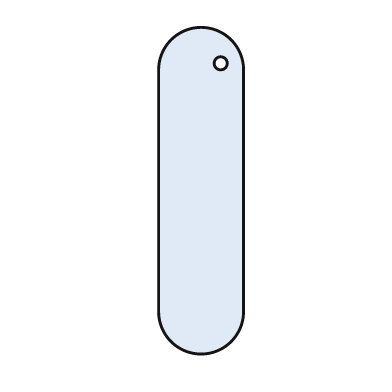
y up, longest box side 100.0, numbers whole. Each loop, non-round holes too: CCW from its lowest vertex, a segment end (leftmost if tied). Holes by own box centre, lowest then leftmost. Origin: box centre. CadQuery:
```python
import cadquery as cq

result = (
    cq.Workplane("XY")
    .moveTo(-13.0, -37.0)
    .threePointArc((0.0, -50.0), (13.0, -37.0))
    .lineTo(13.0, 37.0)
    .threePointArc((0.0, 50.0), (-13.0, 37.0))
    .close()
    .moveTo(6.0, 39.0)
    .circle(2.0)
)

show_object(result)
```